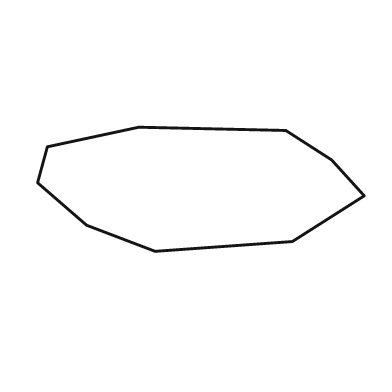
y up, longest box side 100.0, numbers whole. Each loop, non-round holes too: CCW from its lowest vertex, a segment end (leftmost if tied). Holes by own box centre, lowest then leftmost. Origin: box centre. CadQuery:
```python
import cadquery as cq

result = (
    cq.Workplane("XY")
    .moveTo(-14.0, -19.0)
    .lineTo(28.0, -16.0)
    .lineTo(50.0, -2.0)
    .lineTo(40.0, 9.0)
    .lineTo(26.0, 18.0)
    .lineTo(-19.0, 19.0)
    .lineTo(-47.0, 13.0)
    .lineTo(-50.0, 2.0)
    .lineTo(-35.0, -11.0)
    .close()
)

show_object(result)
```